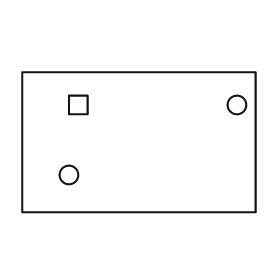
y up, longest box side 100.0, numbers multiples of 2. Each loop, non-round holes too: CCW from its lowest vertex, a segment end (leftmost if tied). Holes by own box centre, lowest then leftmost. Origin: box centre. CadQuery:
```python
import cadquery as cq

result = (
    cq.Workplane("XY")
    .moveTo(-50.0, -30.0)
    .lineTo(50.0, -30.0)
    .lineTo(50.0, 30.0)
    .lineTo(-50.0, 30.0)
    .close()
    .moveTo(-30.0, -14.0)
    .circle(4.0)
    .moveTo(-30.0, 12.0)
    .lineTo(-22.0, 12.0)
    .lineTo(-22.0, 20.0)
    .lineTo(-30.0, 20.0)
    .close()
    .moveTo(42.0, 16.0)
    .circle(4.0)
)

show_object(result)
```